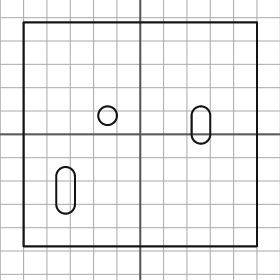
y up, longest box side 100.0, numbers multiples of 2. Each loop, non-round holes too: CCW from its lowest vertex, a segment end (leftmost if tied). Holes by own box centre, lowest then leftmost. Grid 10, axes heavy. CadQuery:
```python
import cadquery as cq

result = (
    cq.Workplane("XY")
    .moveTo(-50.0, -48.0)
    .lineTo(50.0, -48.0)
    .lineTo(50.0, 48.0)
    .lineTo(-50.0, 48.0)
    .close()
    .moveTo(-36.0, -30.0)
    .threePointArc((-32.0, -34.0), (-28.0, -30.0))
    .lineTo(-28.0, -18.0)
    .threePointArc((-32.0, -14.0), (-36.0, -18.0))
    .close()
    .moveTo(22.0, 0.0)
    .threePointArc((26.0, -4.0), (30.0, 0.0))
    .lineTo(30.0, 8.0)
    .threePointArc((26.0, 12.0), (22.0, 8.0))
    .close()
    .moveTo(-14.0, 8.0)
    .circle(4.0)
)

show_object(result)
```